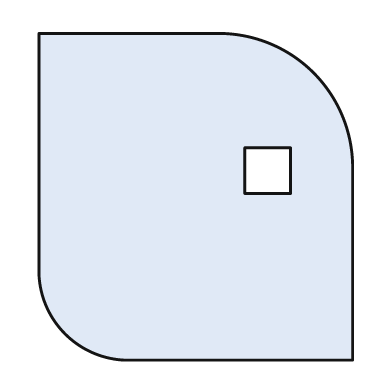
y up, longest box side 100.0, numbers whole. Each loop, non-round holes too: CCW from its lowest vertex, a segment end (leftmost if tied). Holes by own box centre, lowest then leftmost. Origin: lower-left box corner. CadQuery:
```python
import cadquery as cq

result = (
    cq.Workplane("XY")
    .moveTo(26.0, 0.0)
    .lineTo(96.0, 0.0)
    .lineTo(96.0, 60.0)
    .threePointArc((84.0, 88.0), (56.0, 100.0))
    .lineTo(0.0, 100.0)
    .lineTo(0.0, 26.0)
    .threePointArc((8.0, 8.0), (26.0, 0.0))
    .close()
    .moveTo(63.0, 51.0)
    .lineTo(77.0, 51.0)
    .lineTo(77.0, 65.0)
    .lineTo(63.0, 65.0)
    .close()
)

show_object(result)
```